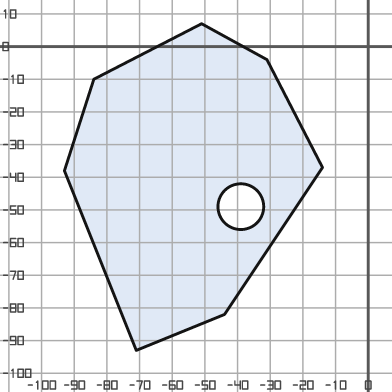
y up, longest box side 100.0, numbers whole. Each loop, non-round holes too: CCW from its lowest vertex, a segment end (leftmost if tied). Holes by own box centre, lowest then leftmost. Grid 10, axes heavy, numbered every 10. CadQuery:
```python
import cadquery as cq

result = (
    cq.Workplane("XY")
    .moveTo(-71.0, -93.0)
    .lineTo(-44.0, -82.0)
    .lineTo(-14.0, -37.0)
    .lineTo(-31.0, -4.0)
    .lineTo(-51.0, 7.0)
    .lineTo(-84.0, -10.0)
    .lineTo(-93.0, -38.0)
    .close()
    .moveTo(-39.0, -49.0)
    .circle(7.0)
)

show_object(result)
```